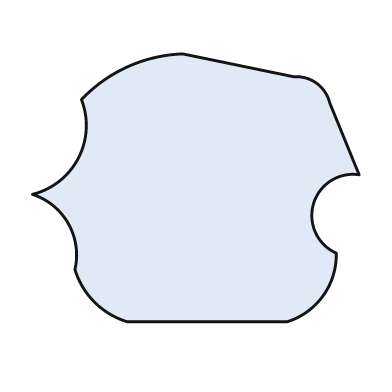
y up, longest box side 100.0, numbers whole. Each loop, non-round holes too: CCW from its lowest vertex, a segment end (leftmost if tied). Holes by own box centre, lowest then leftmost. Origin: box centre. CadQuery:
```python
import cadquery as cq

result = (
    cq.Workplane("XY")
    .moveTo(-21.0, -41.0)
    .lineTo(28.0, -41.0)
    .threePointArc((39.0, -33.0), (43.0, -20.0))
    .threePointArc((36.0, -5.0), (50.0, 4.0))
    .lineTo(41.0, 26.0)
    .threePointArc((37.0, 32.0), (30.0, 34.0))
    .lineTo(-4.0, 41.0)
    .threePointArc((-21.0, 37.0), (-35.0, 27.0))
    .threePointArc((-36.0, 9.0), (-50.0, -2.0))
    .threePointArc((-39.0, -11.0), (-37.0, -25.0))
    .threePointArc((-31.0, -35.0), (-21.0, -41.0))
    .close()
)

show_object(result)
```